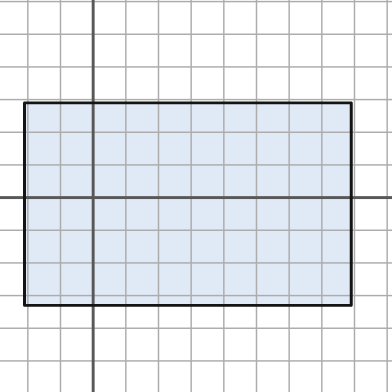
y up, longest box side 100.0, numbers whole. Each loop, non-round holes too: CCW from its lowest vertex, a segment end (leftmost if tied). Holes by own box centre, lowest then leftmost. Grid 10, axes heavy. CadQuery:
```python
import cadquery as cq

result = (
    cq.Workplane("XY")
    .moveTo(-21.0, -33.0)
    .lineTo(79.0, -33.0)
    .lineTo(79.0, 29.0)
    .lineTo(-21.0, 29.0)
    .close()
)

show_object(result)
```